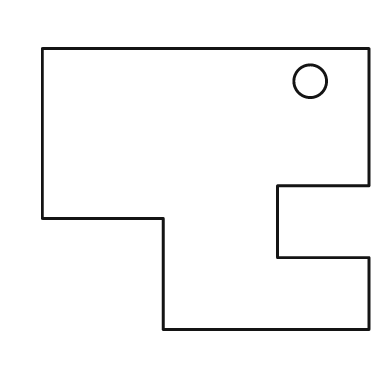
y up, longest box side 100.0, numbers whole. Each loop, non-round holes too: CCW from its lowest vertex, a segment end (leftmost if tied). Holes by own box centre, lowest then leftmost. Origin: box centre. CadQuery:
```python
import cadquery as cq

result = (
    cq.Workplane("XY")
    .moveTo(-13.0, -43.0)
    .lineTo(50.0, -43.0)
    .lineTo(50.0, -21.0)
    .lineTo(22.0, -21.0)
    .lineTo(22.0, 1.0)
    .lineTo(50.0, 1.0)
    .lineTo(50.0, 43.0)
    .lineTo(-50.0, 43.0)
    .lineTo(-50.0, -9.0)
    .lineTo(-13.0, -9.0)
    .close()
    .moveTo(32.0, 33.0)
    .circle(5.0)
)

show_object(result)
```